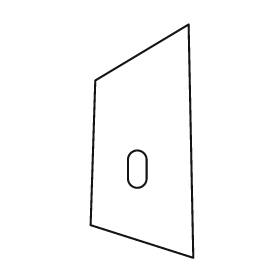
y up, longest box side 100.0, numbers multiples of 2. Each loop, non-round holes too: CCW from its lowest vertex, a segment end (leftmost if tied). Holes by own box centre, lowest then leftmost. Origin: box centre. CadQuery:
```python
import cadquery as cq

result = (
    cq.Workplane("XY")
    .moveTo(22.0, -50.0)
    .lineTo(20.0, 50.0)
    .lineTo(-20.0, 26.0)
    .lineTo(-22.0, -36.0)
    .close()
    .moveTo(-6.0, -16.0)
    .threePointArc((-2.0, -20.0), (2.0, -16.0))
    .lineTo(2.0, -8.0)
    .threePointArc((-2.0, -4.0), (-6.0, -8.0))
    .close()
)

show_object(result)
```